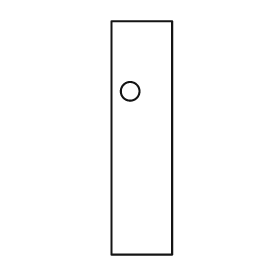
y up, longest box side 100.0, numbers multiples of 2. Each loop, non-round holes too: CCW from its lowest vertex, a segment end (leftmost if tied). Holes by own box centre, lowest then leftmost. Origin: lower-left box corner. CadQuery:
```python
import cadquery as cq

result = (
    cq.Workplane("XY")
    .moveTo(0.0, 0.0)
    .lineTo(26.0, 0.0)
    .lineTo(26.0, 100.0)
    .lineTo(0.0, 100.0)
    .close()
    .moveTo(8.0, 70.0)
    .circle(4.0)
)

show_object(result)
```